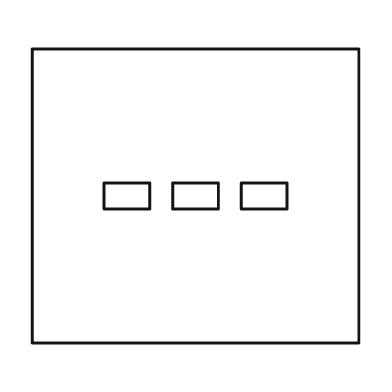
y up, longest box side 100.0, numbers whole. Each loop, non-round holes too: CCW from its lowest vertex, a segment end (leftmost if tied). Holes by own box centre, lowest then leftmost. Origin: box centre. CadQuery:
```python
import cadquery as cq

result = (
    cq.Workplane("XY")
    .moveTo(-50.0, -45.0)
    .lineTo(50.0, -45.0)
    .lineTo(50.0, 45.0)
    .lineTo(-50.0, 45.0)
    .close()
    .moveTo(-28.0, -4.0)
    .lineTo(-14.0, -4.0)
    .lineTo(-14.0, 4.0)
    .lineTo(-28.0, 4.0)
    .close()
    .moveTo(-7.0, -4.0)
    .lineTo(7.0, -4.0)
    .lineTo(7.0, 4.0)
    .lineTo(-7.0, 4.0)
    .close()
    .moveTo(14.0, -4.0)
    .lineTo(28.0, -4.0)
    .lineTo(28.0, 4.0)
    .lineTo(14.0, 4.0)
    .close()
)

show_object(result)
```